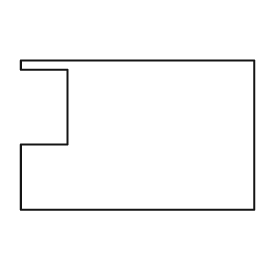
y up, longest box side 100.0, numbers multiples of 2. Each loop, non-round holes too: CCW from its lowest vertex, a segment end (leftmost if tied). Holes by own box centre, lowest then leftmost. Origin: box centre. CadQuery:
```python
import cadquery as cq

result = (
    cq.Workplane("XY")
    .moveTo(-50.0, -32.0)
    .lineTo(50.0, -32.0)
    .lineTo(50.0, 32.0)
    .lineTo(-50.0, 32.0)
    .lineTo(-50.0, 28.0)
    .lineTo(-30.0, 28.0)
    .lineTo(-30.0, -4.0)
    .lineTo(-50.0, -4.0)
    .close()
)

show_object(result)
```